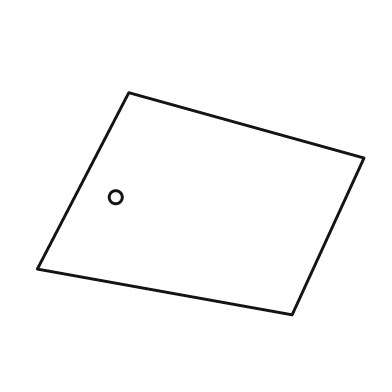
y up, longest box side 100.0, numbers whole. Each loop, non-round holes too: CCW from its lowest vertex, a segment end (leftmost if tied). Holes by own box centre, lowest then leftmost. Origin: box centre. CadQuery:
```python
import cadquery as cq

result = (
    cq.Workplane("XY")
    .moveTo(28.0, -34.0)
    .lineTo(50.0, 14.0)
    .lineTo(-22.0, 34.0)
    .lineTo(-50.0, -20.0)
    .close()
    .moveTo(-26.0, 2.0)
    .circle(2.0)
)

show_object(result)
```